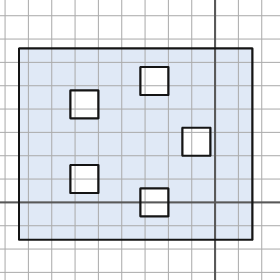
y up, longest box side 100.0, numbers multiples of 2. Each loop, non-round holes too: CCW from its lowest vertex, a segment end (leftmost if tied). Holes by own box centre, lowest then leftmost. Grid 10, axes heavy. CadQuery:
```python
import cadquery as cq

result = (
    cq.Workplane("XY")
    .moveTo(-84.0, -16.0)
    .lineTo(16.0, -16.0)
    .lineTo(16.0, 66.0)
    .lineTo(-84.0, 66.0)
    .close()
    .moveTo(-32.0, -6.0)
    .lineTo(-20.0, -6.0)
    .lineTo(-20.0, 6.0)
    .lineTo(-32.0, 6.0)
    .close()
    .moveTo(-62.0, 4.0)
    .lineTo(-50.0, 4.0)
    .lineTo(-50.0, 16.0)
    .lineTo(-62.0, 16.0)
    .close()
    .moveTo(-14.0, 20.0)
    .lineTo(-2.0, 20.0)
    .lineTo(-2.0, 32.0)
    .lineTo(-14.0, 32.0)
    .close()
    .moveTo(-62.0, 36.0)
    .lineTo(-50.0, 36.0)
    .lineTo(-50.0, 48.0)
    .lineTo(-62.0, 48.0)
    .close()
    .moveTo(-32.0, 46.0)
    .lineTo(-20.0, 46.0)
    .lineTo(-20.0, 58.0)
    .lineTo(-32.0, 58.0)
    .close()
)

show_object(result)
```